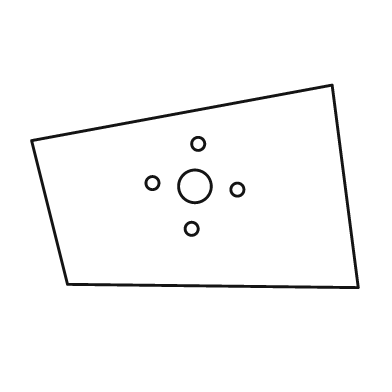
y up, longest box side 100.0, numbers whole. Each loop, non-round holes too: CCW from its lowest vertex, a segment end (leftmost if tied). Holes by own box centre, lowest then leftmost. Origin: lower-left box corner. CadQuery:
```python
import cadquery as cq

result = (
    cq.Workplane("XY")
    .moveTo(100.0, 0.0)
    .lineTo(92.0, 62.0)
    .lineTo(0.0, 45.0)
    .lineTo(11.0, 1.0)
    .close()
    .moveTo(49.0, 18.0)
    .circle(2.0)
    .moveTo(63.0, 30.0)
    .circle(2.0)
    .moveTo(50.0, 31.0)
    .circle(5.0)
    .moveTo(37.0, 32.0)
    .circle(2.0)
    .moveTo(51.0, 44.0)
    .circle(2.0)
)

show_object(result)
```